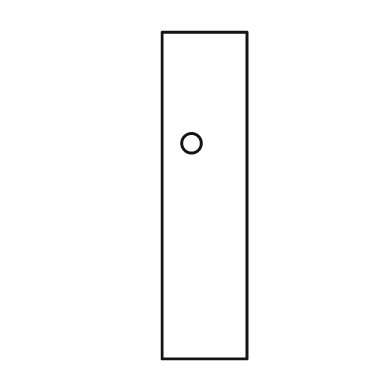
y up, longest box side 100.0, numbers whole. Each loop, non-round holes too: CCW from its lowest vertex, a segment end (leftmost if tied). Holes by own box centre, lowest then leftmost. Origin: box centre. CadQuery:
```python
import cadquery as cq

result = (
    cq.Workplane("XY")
    .moveTo(-13.0, -50.0)
    .lineTo(13.0, -50.0)
    .lineTo(13.0, 50.0)
    .lineTo(-13.0, 50.0)
    .close()
    .moveTo(-4.0, 16.0)
    .circle(3.0)
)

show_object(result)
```